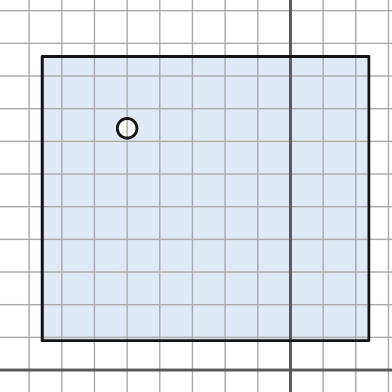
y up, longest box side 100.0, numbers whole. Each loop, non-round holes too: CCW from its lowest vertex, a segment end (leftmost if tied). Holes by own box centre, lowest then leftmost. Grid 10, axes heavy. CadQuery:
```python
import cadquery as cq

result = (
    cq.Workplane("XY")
    .moveTo(-76.0, 9.0)
    .lineTo(24.0, 9.0)
    .lineTo(24.0, 96.0)
    .lineTo(-76.0, 96.0)
    .close()
    .moveTo(-50.0, 74.0)
    .circle(3.0)
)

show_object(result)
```